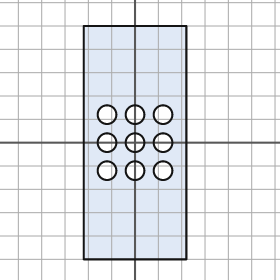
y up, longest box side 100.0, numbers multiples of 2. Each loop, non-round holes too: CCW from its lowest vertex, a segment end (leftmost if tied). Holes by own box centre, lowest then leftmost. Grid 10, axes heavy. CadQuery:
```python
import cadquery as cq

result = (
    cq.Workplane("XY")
    .moveTo(-22.0, -50.0)
    .lineTo(22.0, -50.0)
    .lineTo(22.0, 50.0)
    .lineTo(-22.0, 50.0)
    .close()
    .moveTo(-12.0, -12.0)
    .circle(4.0)
    .moveTo(0.0, -12.0)
    .circle(4.0)
    .moveTo(12.0, -12.0)
    .circle(4.0)
    .moveTo(-12.0, 0.0)
    .circle(4.0)
    .moveTo(0.0, 0.0)
    .circle(4.0)
    .moveTo(12.0, 0.0)
    .circle(4.0)
    .moveTo(-12.0, 12.0)
    .circle(4.0)
    .moveTo(0.0, 12.0)
    .circle(4.0)
    .moveTo(12.0, 12.0)
    .circle(4.0)
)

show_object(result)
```